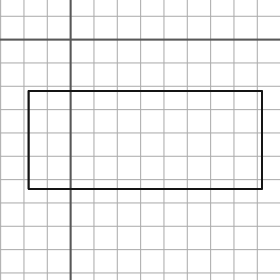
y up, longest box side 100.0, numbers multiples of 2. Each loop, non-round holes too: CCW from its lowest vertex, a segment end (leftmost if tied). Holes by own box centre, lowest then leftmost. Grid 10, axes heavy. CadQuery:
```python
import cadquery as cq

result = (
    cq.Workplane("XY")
    .moveTo(-18.0, -64.0)
    .lineTo(82.0, -64.0)
    .lineTo(82.0, -22.0)
    .lineTo(-18.0, -22.0)
    .close()
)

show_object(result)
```